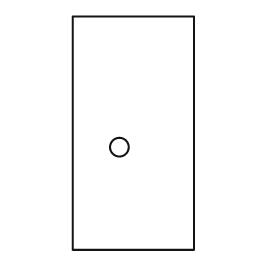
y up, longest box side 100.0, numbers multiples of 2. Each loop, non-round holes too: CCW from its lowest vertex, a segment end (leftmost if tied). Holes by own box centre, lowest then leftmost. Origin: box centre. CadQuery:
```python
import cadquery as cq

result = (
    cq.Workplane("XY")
    .moveTo(-26.0, -50.0)
    .lineTo(26.0, -50.0)
    .lineTo(26.0, 50.0)
    .lineTo(-26.0, 50.0)
    .close()
    .moveTo(-6.0, -6.0)
    .circle(4.0)
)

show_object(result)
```